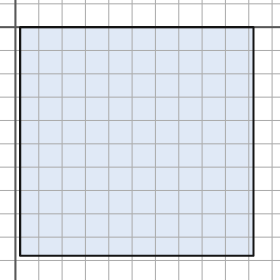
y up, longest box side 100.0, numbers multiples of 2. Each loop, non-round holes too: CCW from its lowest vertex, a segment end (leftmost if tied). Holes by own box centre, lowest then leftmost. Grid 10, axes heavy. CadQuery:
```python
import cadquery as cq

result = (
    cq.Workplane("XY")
    .moveTo(2.0, -98.0)
    .lineTo(102.0, -98.0)
    .lineTo(102.0, 0.0)
    .lineTo(2.0, 0.0)
    .close()
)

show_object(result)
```